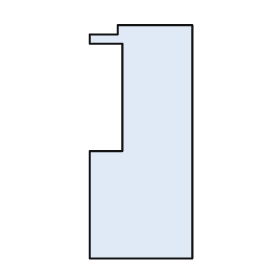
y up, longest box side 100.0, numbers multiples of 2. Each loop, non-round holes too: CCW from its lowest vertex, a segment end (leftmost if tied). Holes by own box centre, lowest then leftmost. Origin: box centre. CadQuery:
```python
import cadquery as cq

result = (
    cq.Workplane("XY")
    .moveTo(-22.0, -50.0)
    .lineTo(22.0, -50.0)
    .lineTo(22.0, 50.0)
    .lineTo(-10.0, 50.0)
    .lineTo(-10.0, 46.0)
    .lineTo(-22.0, 46.0)
    .lineTo(-22.0, 42.0)
    .lineTo(-8.0, 42.0)
    .lineTo(-8.0, -4.0)
    .lineTo(-22.0, -4.0)
    .close()
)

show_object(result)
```